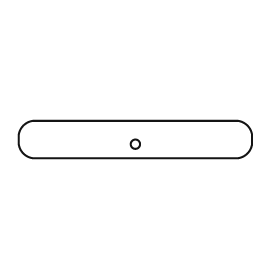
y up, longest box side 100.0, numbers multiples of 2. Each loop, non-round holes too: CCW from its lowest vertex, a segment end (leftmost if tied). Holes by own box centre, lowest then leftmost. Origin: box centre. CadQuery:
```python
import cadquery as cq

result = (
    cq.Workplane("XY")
    .moveTo(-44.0, -8.0)
    .lineTo(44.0, -8.0)
    .threePointArc((48.0, -6.0), (50.0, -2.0))
    .lineTo(50.0, 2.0)
    .threePointArc((48.0, 6.0), (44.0, 8.0))
    .lineTo(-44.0, 8.0)
    .threePointArc((-48.0, 6.0), (-50.0, 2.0))
    .lineTo(-50.0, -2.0)
    .threePointArc((-48.0, -6.0), (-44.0, -8.0))
    .close()
    .moveTo(0.0, -2.0)
    .circle(2.0)
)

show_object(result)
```